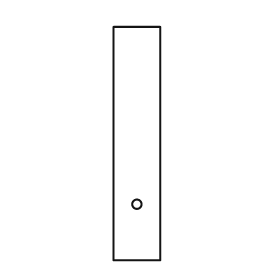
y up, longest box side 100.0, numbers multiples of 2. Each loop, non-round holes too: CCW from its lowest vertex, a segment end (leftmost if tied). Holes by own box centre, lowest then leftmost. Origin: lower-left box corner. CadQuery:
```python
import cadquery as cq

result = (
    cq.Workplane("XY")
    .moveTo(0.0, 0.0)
    .lineTo(20.0, 0.0)
    .lineTo(20.0, 100.0)
    .lineTo(0.0, 100.0)
    .close()
    .moveTo(10.0, 24.0)
    .circle(2.0)
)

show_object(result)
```